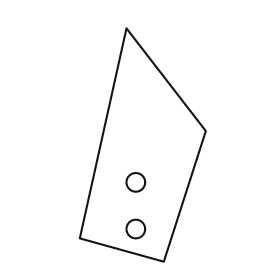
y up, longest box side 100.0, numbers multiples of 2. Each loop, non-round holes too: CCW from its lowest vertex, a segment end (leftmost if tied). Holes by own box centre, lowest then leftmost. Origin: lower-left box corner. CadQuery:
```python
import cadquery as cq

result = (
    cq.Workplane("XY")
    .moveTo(36.0, 0.0)
    .lineTo(54.0, 56.0)
    .lineTo(20.0, 100.0)
    .lineTo(0.0, 10.0)
    .close()
    .moveTo(24.0, 14.0)
    .circle(4.0)
    .moveTo(24.0, 34.0)
    .circle(4.0)
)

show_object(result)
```